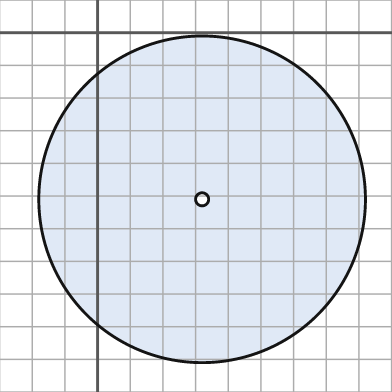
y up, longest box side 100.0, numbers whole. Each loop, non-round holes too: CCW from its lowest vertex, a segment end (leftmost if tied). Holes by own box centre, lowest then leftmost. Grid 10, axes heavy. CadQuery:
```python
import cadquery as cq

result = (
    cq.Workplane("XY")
    .moveTo(32.0, -51.0)
    .circle(50.0)
    .moveTo(32.0, -51.0)
    .circle(2.0)
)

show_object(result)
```